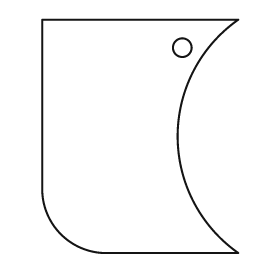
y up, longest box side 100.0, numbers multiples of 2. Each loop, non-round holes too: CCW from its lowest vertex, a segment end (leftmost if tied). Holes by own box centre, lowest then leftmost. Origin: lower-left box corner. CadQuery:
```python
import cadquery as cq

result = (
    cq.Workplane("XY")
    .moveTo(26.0, 0.0)
    .lineTo(84.0, 0.0)
    .threePointArc((58.0, 50.0), (84.0, 100.0))
    .lineTo(0.0, 100.0)
    .lineTo(0.0, 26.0)
    .threePointArc((8.0, 8.0), (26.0, 0.0))
    .close()
    .moveTo(60.0, 88.0)
    .circle(4.0)
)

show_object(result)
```